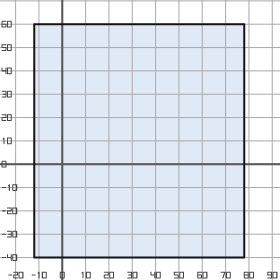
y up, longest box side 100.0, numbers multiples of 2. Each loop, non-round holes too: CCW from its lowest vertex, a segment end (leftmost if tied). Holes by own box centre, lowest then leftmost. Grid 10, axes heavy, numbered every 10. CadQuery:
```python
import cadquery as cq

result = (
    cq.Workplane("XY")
    .moveTo(-12.0, -40.0)
    .lineTo(78.0, -40.0)
    .lineTo(78.0, 60.0)
    .lineTo(-12.0, 60.0)
    .close()
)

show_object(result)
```